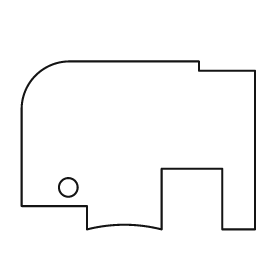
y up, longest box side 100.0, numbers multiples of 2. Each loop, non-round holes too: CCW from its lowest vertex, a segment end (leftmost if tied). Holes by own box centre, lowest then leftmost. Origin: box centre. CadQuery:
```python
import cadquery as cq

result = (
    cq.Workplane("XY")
    .moveTo(-22.0, -36.0)
    .threePointArc((-6.0, -34.0), (10.0, -36.0))
    .lineTo(10.0, -10.0)
    .lineTo(36.0, -10.0)
    .lineTo(36.0, -36.0)
    .lineTo(50.0, -36.0)
    .lineTo(50.0, 32.0)
    .lineTo(26.0, 32.0)
    .lineTo(26.0, 36.0)
    .lineTo(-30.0, 36.0)
    .threePointArc((-44.0, 30.0), (-50.0, 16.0))
    .lineTo(-50.0, -26.0)
    .lineTo(-22.0, -26.0)
    .close()
    .moveTo(-30.0, -18.0)
    .circle(4.0)
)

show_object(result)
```